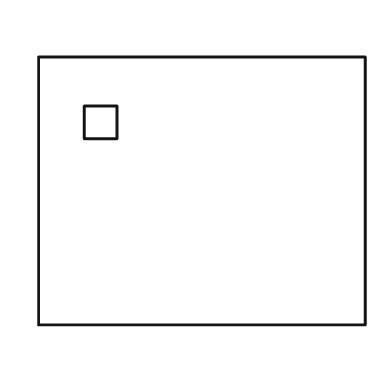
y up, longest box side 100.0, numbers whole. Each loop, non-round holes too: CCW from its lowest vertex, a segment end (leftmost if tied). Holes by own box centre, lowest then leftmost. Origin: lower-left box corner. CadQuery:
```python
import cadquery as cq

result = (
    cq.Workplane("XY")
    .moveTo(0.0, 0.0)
    .lineTo(100.0, 0.0)
    .lineTo(100.0, 82.0)
    .lineTo(0.0, 82.0)
    .close()
    .moveTo(14.0, 57.0)
    .lineTo(24.0, 57.0)
    .lineTo(24.0, 67.0)
    .lineTo(14.0, 67.0)
    .close()
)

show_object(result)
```